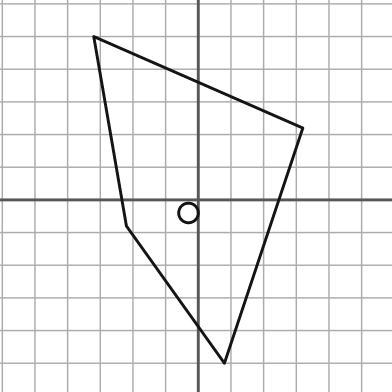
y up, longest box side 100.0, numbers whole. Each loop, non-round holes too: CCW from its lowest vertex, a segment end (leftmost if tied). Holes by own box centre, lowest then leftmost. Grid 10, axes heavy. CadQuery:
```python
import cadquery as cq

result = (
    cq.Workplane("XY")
    .moveTo(8.0, -50.0)
    .lineTo(32.0, 22.0)
    .lineTo(-32.0, 50.0)
    .lineTo(-22.0, -8.0)
    .close()
    .moveTo(-3.0, -4.0)
    .circle(3.0)
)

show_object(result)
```